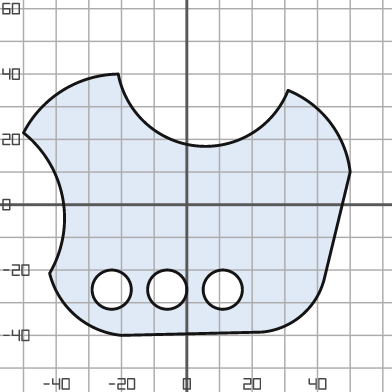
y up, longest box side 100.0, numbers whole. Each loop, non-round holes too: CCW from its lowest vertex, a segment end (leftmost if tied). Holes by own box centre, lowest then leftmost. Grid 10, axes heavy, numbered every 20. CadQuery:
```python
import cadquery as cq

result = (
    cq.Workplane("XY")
    .moveTo(-20.0, -40.0)
    .lineTo(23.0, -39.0)
    .threePointArc((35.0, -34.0), (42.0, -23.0))
    .lineTo(50.0, 10.0)
    .threePointArc((44.0, 25.0), (31.0, 35.0))
    .threePointArc((3.0, 18.0), (-21.0, 40.0))
    .threePointArc((-38.0, 35.0), (-50.0, 22.0))
    .threePointArc((-38.0, 2.0), (-42.0, -21.0))
    .threePointArc((-34.0, -34.0), (-20.0, -40.0))
    .close()
    .moveTo(-23.0, -26.0)
    .circle(6.0)
    .moveTo(-6.0, -26.0)
    .circle(6.0)
    .moveTo(11.0, -26.0)
    .circle(6.0)
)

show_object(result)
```